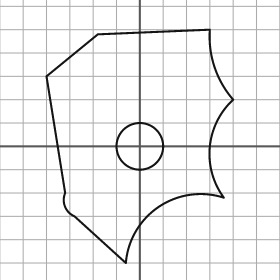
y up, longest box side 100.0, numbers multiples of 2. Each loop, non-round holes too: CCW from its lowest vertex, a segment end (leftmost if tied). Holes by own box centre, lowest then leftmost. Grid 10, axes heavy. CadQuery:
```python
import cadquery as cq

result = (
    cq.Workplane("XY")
    .moveTo(-6.0, -50.0)
    .threePointArc((8.0, -26.0), (36.0, -22.0))
    .threePointArc((30.0, 0.0), (40.0, 20.0))
    .threePointArc((32.0, 34.0), (30.0, 50.0))
    .lineTo(-18.0, 48.0)
    .lineTo(-40.0, 30.0)
    .lineTo(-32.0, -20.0)
    .threePointArc((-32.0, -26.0), (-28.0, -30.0))
    .close()
    .moveTo(0.0, 0.0)
    .circle(10.0)
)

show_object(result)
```